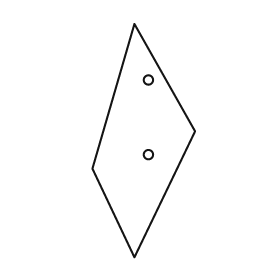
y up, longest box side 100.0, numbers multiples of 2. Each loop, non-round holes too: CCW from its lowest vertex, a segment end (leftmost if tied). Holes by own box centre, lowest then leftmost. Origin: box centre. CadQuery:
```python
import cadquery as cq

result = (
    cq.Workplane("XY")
    .moveTo(-4.0, -50.0)
    .lineTo(22.0, 4.0)
    .lineTo(-4.0, 50.0)
    .lineTo(-22.0, -12.0)
    .close()
    .moveTo(2.0, -6.0)
    .circle(2.0)
    .moveTo(2.0, 26.0)
    .circle(2.0)
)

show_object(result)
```